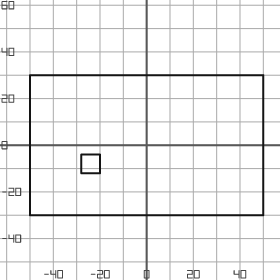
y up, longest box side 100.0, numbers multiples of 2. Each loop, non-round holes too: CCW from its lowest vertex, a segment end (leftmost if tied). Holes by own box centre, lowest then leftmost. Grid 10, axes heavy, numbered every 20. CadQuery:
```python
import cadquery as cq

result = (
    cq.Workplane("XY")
    .moveTo(-50.0, -30.0)
    .lineTo(50.0, -30.0)
    .lineTo(50.0, 30.0)
    .lineTo(-50.0, 30.0)
    .close()
    .moveTo(-28.0, -12.0)
    .lineTo(-20.0, -12.0)
    .lineTo(-20.0, -4.0)
    .lineTo(-28.0, -4.0)
    .close()
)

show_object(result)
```